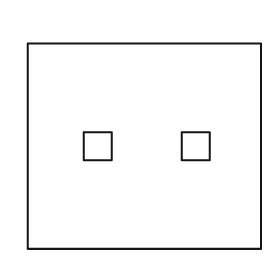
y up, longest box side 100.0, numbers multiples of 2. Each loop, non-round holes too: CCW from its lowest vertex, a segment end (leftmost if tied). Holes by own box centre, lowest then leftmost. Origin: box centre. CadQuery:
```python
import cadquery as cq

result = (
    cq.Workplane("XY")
    .moveTo(-50.0, -44.0)
    .lineTo(50.0, -44.0)
    .lineTo(50.0, 44.0)
    .lineTo(-50.0, 44.0)
    .close()
    .moveTo(-26.0, -6.0)
    .lineTo(-14.0, -6.0)
    .lineTo(-14.0, 6.0)
    .lineTo(-26.0, 6.0)
    .close()
    .moveTo(16.0, -6.0)
    .lineTo(28.0, -6.0)
    .lineTo(28.0, 6.0)
    .lineTo(16.0, 6.0)
    .close()
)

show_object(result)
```